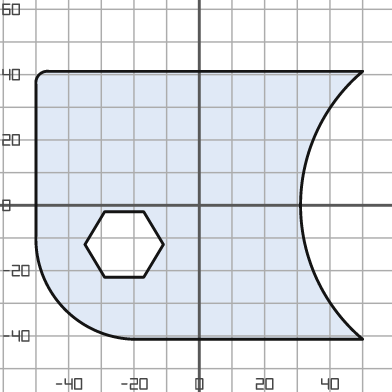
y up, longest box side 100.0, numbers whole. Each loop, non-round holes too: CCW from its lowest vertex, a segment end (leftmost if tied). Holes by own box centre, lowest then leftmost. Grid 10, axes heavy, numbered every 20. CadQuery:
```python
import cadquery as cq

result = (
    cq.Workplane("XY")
    .moveTo(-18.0, -41.0)
    .lineTo(50.0, -41.0)
    .threePointArc((31.0, 0.0), (50.0, 41.0))
    .lineTo(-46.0, 41.0)
    .threePointArc((-49.0, 40.0), (-50.0, 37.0))
    .lineTo(-50.0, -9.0)
    .threePointArc((-41.0, -32.0), (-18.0, -41.0))
    .close()
    .moveTo(-29.0, -22.0)
    .lineTo(-17.0, -22.0)
    .lineTo(-11.0, -12.0)
    .lineTo(-17.0, -2.0)
    .lineTo(-29.0, -2.0)
    .lineTo(-35.0, -12.0)
    .close()
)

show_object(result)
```